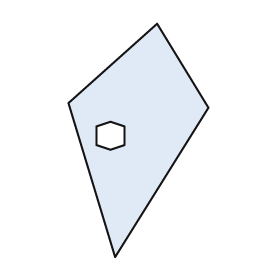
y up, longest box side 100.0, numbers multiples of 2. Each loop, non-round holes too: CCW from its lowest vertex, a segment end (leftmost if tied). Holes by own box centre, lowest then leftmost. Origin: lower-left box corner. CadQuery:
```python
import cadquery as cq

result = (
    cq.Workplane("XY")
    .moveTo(20.0, 0.0)
    .lineTo(60.0, 64.0)
    .lineTo(38.0, 100.0)
    .lineTo(0.0, 66.0)
    .close()
    .moveTo(18.0, 46.0)
    .lineTo(24.0, 48.0)
    .lineTo(24.0, 56.0)
    .lineTo(18.0, 58.0)
    .lineTo(12.0, 56.0)
    .lineTo(12.0, 48.0)
    .close()
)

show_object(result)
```